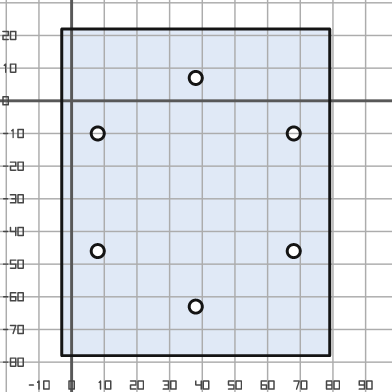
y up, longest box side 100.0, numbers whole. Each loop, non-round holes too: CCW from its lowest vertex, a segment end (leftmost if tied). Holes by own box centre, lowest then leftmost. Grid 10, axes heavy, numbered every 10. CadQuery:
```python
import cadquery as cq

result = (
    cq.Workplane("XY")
    .moveTo(-3.0, -78.0)
    .lineTo(79.0, -78.0)
    .lineTo(79.0, 22.0)
    .lineTo(-3.0, 22.0)
    .close()
    .moveTo(38.0, -63.0)
    .circle(2.0)
    .moveTo(8.0, -46.0)
    .circle(2.0)
    .moveTo(68.0, -46.0)
    .circle(2.0)
    .moveTo(8.0, -10.0)
    .circle(2.0)
    .moveTo(68.0, -10.0)
    .circle(2.0)
    .moveTo(38.0, 7.0)
    .circle(2.0)
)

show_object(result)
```